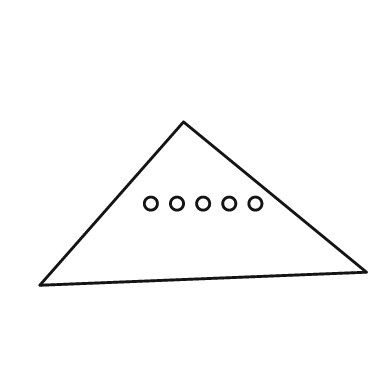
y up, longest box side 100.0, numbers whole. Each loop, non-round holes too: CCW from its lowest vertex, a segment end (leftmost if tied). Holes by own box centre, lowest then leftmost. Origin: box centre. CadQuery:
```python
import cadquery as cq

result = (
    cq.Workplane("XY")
    .moveTo(-50.0, -25.0)
    .lineTo(50.0, -21.0)
    .lineTo(-6.0, 25.0)
    .close()
    .moveTo(-16.0, 0.0)
    .circle(2.0)
    .moveTo(-8.0, 0.0)
    .circle(2.0)
    .moveTo(0.0, 0.0)
    .circle(2.0)
    .moveTo(8.0, 0.0)
    .circle(2.0)
    .moveTo(16.0, 0.0)
    .circle(2.0)
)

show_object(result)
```